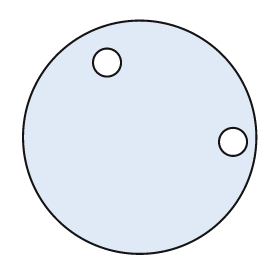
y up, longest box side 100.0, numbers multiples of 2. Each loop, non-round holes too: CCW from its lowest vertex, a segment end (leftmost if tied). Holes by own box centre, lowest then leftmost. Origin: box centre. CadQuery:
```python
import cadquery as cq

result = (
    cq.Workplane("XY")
    .moveTo(0.0, 0.0)
    .circle(50.0)
    .moveTo(40.0, -2.0)
    .circle(6.0)
    .moveTo(-14.0, 32.0)
    .circle(6.0)
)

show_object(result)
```